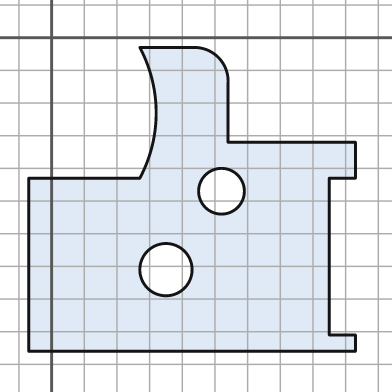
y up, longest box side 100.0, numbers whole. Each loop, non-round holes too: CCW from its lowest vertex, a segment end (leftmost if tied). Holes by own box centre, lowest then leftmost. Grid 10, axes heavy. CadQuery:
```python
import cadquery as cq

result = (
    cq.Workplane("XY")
    .moveTo(-7.0, -96.0)
    .lineTo(93.0, -96.0)
    .lineTo(93.0, -91.0)
    .lineTo(85.0, -91.0)
    .lineTo(85.0, -43.0)
    .lineTo(93.0, -43.0)
    .lineTo(93.0, -32.0)
    .lineTo(54.0, -32.0)
    .lineTo(54.0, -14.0)
    .threePointArc((51.0, -6.0), (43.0, -3.0))
    .lineTo(27.0, -3.0)
    .threePointArc((32.0, -23.0), (27.0, -43.0))
    .lineTo(-7.0, -43.0)
    .close()
    .moveTo(35.0, -71.0)
    .circle(8.0)
    .moveTo(52.0, -47.0)
    .circle(7.0)
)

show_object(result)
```